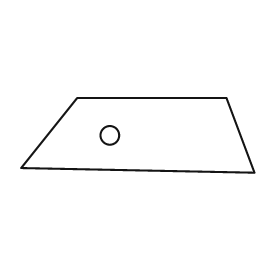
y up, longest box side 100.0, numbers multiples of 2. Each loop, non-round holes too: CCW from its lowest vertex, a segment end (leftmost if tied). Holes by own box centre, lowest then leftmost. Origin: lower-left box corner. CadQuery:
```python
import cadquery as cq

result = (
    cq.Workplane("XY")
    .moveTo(100.0, 0.0)
    .lineTo(88.0, 32.0)
    .lineTo(24.0, 32.0)
    .lineTo(0.0, 2.0)
    .close()
    .moveTo(38.0, 16.0)
    .circle(4.0)
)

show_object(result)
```